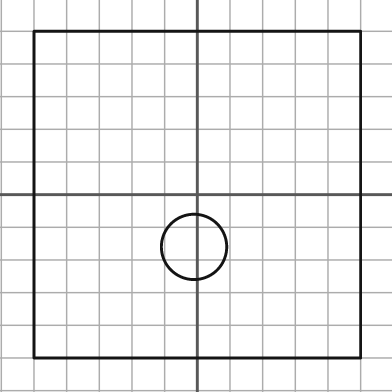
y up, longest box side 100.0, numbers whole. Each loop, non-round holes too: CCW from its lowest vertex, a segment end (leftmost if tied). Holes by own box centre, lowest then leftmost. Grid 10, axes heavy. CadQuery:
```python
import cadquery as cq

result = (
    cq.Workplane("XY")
    .moveTo(-50.0, -50.0)
    .lineTo(50.0, -50.0)
    .lineTo(50.0, 50.0)
    .lineTo(-50.0, 50.0)
    .close()
    .moveTo(-1.0, -16.0)
    .circle(10.0)
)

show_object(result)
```